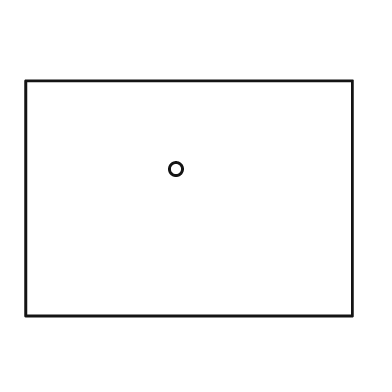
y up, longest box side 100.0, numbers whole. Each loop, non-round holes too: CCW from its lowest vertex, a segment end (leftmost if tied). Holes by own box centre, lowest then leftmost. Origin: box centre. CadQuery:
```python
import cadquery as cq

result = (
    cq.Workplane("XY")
    .moveTo(-50.0, -36.0)
    .lineTo(50.0, -36.0)
    .lineTo(50.0, 36.0)
    .lineTo(-50.0, 36.0)
    .close()
    .moveTo(-4.0, 9.0)
    .circle(2.0)
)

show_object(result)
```